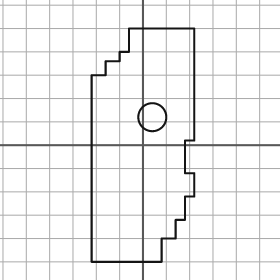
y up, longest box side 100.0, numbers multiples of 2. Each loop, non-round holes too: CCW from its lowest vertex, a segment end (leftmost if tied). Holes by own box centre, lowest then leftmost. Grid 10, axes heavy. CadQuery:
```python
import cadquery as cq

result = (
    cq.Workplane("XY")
    .moveTo(-22.0, -50.0)
    .lineTo(8.0, -50.0)
    .lineTo(8.0, -40.0)
    .lineTo(14.0, -40.0)
    .lineTo(14.0, -32.0)
    .lineTo(18.0, -32.0)
    .lineTo(18.0, -22.0)
    .lineTo(22.0, -22.0)
    .lineTo(22.0, -12.0)
    .lineTo(18.0, -12.0)
    .lineTo(18.0, 2.0)
    .lineTo(22.0, 2.0)
    .lineTo(22.0, 50.0)
    .lineTo(-6.0, 50.0)
    .lineTo(-6.0, 40.0)
    .lineTo(-10.0, 40.0)
    .lineTo(-10.0, 36.0)
    .lineTo(-16.0, 36.0)
    .lineTo(-16.0, 30.0)
    .lineTo(-22.0, 30.0)
    .close()
    .moveTo(4.0, 12.0)
    .circle(6.0)
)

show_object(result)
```